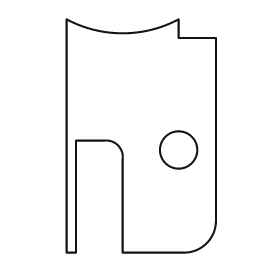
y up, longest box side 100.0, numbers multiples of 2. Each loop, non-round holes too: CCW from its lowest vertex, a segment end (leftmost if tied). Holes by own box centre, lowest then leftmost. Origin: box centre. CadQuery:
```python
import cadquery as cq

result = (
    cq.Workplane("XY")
    .moveTo(-32.0, -50.0)
    .lineTo(-28.0, -50.0)
    .lineTo(-28.0, -2.0)
    .lineTo(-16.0, -2.0)
    .threePointArc((-10.0, -4.0), (-8.0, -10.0))
    .lineTo(-8.0, -50.0)
    .lineTo(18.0, -50.0)
    .threePointArc((28.0, -46.0), (32.0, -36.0))
    .lineTo(32.0, 42.0)
    .lineTo(16.0, 42.0)
    .lineTo(16.0, 50.0)
    .threePointArc((-8.0, 44.0), (-32.0, 50.0))
    .close()
    .moveTo(16.0, -6.0)
    .circle(8.0)
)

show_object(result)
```